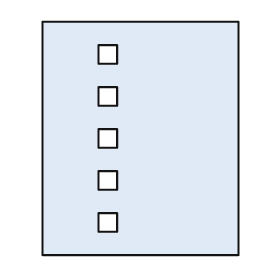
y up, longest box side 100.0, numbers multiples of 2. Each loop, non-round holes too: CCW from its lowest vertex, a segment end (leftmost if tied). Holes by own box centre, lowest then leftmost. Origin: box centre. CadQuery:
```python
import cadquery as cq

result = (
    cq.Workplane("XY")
    .moveTo(-42.0, -50.0)
    .lineTo(42.0, -50.0)
    .lineTo(42.0, 50.0)
    .lineTo(-42.0, 50.0)
    .close()
    .moveTo(-18.0, -40.0)
    .lineTo(-10.0, -40.0)
    .lineTo(-10.0, -32.0)
    .lineTo(-18.0, -32.0)
    .close()
    .moveTo(-18.0, -22.0)
    .lineTo(-10.0, -22.0)
    .lineTo(-10.0, -14.0)
    .lineTo(-18.0, -14.0)
    .close()
    .moveTo(-18.0, -4.0)
    .lineTo(-10.0, -4.0)
    .lineTo(-10.0, 4.0)
    .lineTo(-18.0, 4.0)
    .close()
    .moveTo(-18.0, 14.0)
    .lineTo(-10.0, 14.0)
    .lineTo(-10.0, 22.0)
    .lineTo(-18.0, 22.0)
    .close()
    .moveTo(-18.0, 32.0)
    .lineTo(-10.0, 32.0)
    .lineTo(-10.0, 40.0)
    .lineTo(-18.0, 40.0)
    .close()
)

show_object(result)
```